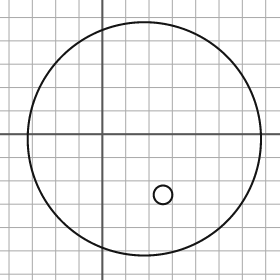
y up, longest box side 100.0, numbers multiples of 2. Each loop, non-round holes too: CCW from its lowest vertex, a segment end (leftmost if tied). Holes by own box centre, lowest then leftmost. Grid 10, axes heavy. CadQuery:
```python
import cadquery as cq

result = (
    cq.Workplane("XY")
    .moveTo(18.0, -2.0)
    .circle(50.0)
    .moveTo(26.0, -26.0)
    .circle(4.0)
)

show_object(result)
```